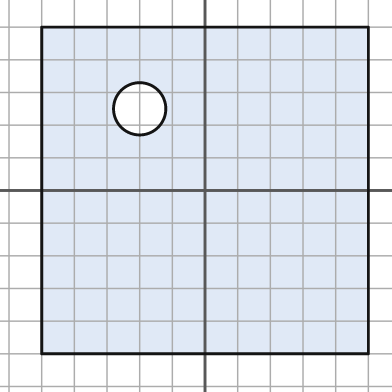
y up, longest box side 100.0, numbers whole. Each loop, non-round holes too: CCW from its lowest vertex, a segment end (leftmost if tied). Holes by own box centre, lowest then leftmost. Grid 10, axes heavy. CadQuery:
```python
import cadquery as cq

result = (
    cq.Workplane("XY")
    .moveTo(-50.0, -50.0)
    .lineTo(50.0, -50.0)
    .lineTo(50.0, 50.0)
    .lineTo(-50.0, 50.0)
    .close()
    .moveTo(-20.0, 25.0)
    .circle(8.0)
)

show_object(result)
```